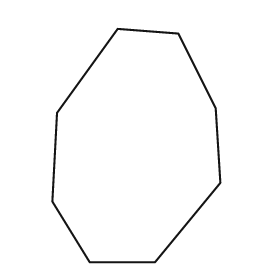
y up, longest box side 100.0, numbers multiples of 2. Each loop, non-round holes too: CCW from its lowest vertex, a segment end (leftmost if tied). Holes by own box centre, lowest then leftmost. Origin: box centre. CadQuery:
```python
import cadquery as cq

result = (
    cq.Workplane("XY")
    .moveTo(-20.0, -50.0)
    .lineTo(8.0, -50.0)
    .lineTo(36.0, -16.0)
    .lineTo(34.0, 16.0)
    .lineTo(18.0, 48.0)
    .lineTo(-8.0, 50.0)
    .lineTo(-34.0, 14.0)
    .lineTo(-36.0, -24.0)
    .close()
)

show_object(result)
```